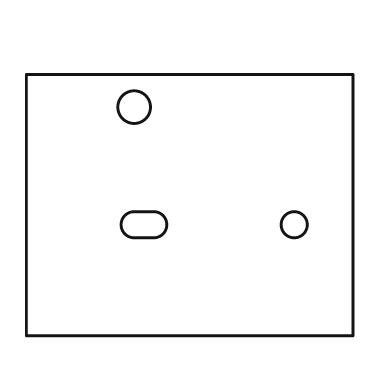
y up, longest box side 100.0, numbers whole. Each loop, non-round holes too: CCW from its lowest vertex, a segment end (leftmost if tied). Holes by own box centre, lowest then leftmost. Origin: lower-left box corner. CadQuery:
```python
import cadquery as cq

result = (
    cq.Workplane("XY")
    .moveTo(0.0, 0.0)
    .lineTo(100.0, 0.0)
    .lineTo(100.0, 80.0)
    .lineTo(0.0, 80.0)
    .close()
    .moveTo(33.0, 30.0)
    .lineTo(39.0, 30.0)
    .threePointArc((43.0, 34.0), (39.0, 38.0))
    .lineTo(33.0, 38.0)
    .threePointArc((29.0, 34.0), (33.0, 30.0))
    .close()
    .moveTo(82.0, 34.0)
    .circle(4.0)
    .moveTo(33.0, 70.0)
    .circle(5.0)
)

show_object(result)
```